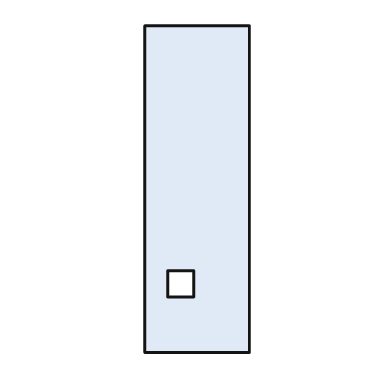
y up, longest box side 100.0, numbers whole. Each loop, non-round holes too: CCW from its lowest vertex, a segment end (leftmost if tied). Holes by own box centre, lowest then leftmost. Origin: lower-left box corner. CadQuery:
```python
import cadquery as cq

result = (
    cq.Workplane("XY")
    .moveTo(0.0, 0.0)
    .lineTo(32.0, 0.0)
    .lineTo(32.0, 100.0)
    .lineTo(0.0, 100.0)
    .close()
    .moveTo(7.0, 17.0)
    .lineTo(15.0, 17.0)
    .lineTo(15.0, 25.0)
    .lineTo(7.0, 25.0)
    .close()
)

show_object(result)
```